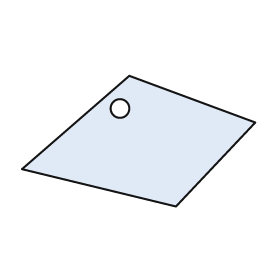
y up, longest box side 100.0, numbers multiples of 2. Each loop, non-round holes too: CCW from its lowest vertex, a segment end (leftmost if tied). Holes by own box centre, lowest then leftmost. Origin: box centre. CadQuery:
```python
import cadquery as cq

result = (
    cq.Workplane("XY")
    .moveTo(16.0, -28.0)
    .lineTo(50.0, 8.0)
    .lineTo(-4.0, 28.0)
    .lineTo(-50.0, -12.0)
    .close()
    .moveTo(-8.0, 14.0)
    .circle(4.0)
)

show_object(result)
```